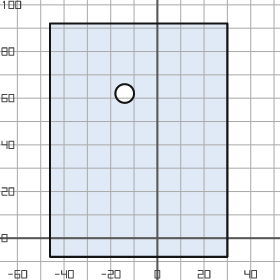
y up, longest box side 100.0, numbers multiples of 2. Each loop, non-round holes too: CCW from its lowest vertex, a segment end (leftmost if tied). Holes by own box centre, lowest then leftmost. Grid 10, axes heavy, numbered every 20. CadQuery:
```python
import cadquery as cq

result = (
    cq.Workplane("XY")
    .moveTo(-46.0, -8.0)
    .lineTo(30.0, -8.0)
    .lineTo(30.0, 92.0)
    .lineTo(-46.0, 92.0)
    .close()
    .moveTo(-14.0, 62.0)
    .circle(4.0)
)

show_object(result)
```